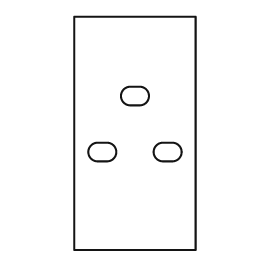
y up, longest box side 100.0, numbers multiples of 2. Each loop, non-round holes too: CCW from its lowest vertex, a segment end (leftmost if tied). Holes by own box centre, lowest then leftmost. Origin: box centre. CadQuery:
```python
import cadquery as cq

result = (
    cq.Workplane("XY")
    .moveTo(-26.0, -50.0)
    .lineTo(26.0, -50.0)
    .lineTo(26.0, 50.0)
    .lineTo(-26.0, 50.0)
    .close()
    .moveTo(-16.0, -12.0)
    .lineTo(-12.0, -12.0)
    .threePointArc((-8.0, -8.0), (-12.0, -4.0))
    .lineTo(-16.0, -4.0)
    .threePointArc((-20.0, -8.0), (-16.0, -12.0))
    .close()
    .moveTo(12.0, -12.0)
    .lineTo(16.0, -12.0)
    .threePointArc((20.0, -8.0), (16.0, -4.0))
    .lineTo(12.0, -4.0)
    .threePointArc((8.0, -8.0), (12.0, -12.0))
    .close()
    .moveTo(-2.0, 12.0)
    .lineTo(2.0, 12.0)
    .threePointArc((6.0, 16.0), (2.0, 20.0))
    .lineTo(-2.0, 20.0)
    .threePointArc((-6.0, 16.0), (-2.0, 12.0))
    .close()
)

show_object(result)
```